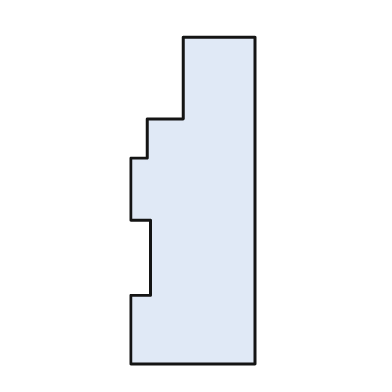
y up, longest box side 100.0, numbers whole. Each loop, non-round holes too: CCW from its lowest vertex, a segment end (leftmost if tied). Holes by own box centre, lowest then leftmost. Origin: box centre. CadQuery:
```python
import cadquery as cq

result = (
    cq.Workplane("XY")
    .moveTo(-19.0, -50.0)
    .lineTo(19.0, -50.0)
    .lineTo(19.0, 50.0)
    .lineTo(-3.0, 50.0)
    .lineTo(-3.0, 25.0)
    .lineTo(-14.0, 25.0)
    .lineTo(-14.0, 13.0)
    .lineTo(-19.0, 13.0)
    .lineTo(-19.0, -6.0)
    .lineTo(-13.0, -6.0)
    .lineTo(-13.0, -29.0)
    .lineTo(-19.0, -29.0)
    .close()
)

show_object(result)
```